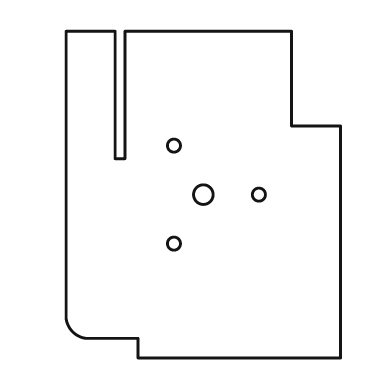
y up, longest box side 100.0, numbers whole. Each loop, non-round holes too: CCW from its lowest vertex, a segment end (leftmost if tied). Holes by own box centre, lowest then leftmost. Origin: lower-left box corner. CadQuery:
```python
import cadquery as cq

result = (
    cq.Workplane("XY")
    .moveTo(22.0, 0.0)
    .lineTo(84.0, 0.0)
    .lineTo(84.0, 71.0)
    .lineTo(69.0, 71.0)
    .lineTo(69.0, 100.0)
    .lineTo(18.0, 100.0)
    .lineTo(18.0, 61.0)
    .lineTo(15.0, 61.0)
    .lineTo(15.0, 100.0)
    .lineTo(0.0, 100.0)
    .lineTo(0.0, 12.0)
    .threePointArc((2.0, 8.0), (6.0, 6.0))
    .lineTo(22.0, 6.0)
    .close()
    .moveTo(33.0, 35.0)
    .circle(2.0)
    .moveTo(42.0, 50.0)
    .circle(3.0)
    .moveTo(59.0, 50.0)
    .circle(2.0)
    .moveTo(33.0, 65.0)
    .circle(2.0)
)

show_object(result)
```